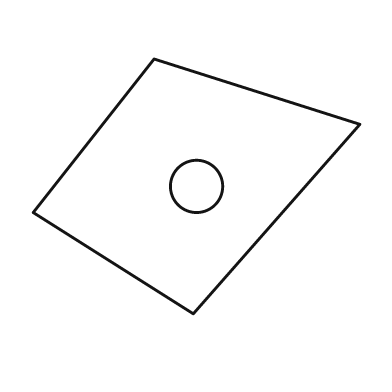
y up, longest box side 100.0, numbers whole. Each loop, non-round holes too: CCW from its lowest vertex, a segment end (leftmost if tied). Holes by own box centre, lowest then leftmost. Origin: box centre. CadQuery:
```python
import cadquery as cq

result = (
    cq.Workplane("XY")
    .moveTo(-1.0, -39.0)
    .lineTo(50.0, 19.0)
    .lineTo(-13.0, 39.0)
    .lineTo(-50.0, -8.0)
    .close()
    .moveTo(0.0, 0.0)
    .circle(8.0)
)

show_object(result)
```